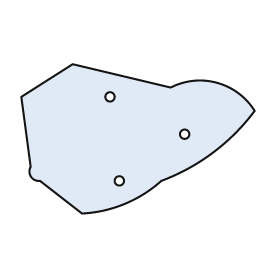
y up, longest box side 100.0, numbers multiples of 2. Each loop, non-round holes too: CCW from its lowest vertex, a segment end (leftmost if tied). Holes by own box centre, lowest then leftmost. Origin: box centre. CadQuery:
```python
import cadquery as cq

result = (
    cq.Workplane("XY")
    .moveTo(-24.0, -32.0)
    .threePointArc((-6.0, -28.0), (10.0, -18.0))
    .threePointArc((32.0, -6.0), (50.0, 12.0))
    .threePointArc((34.0, 24.0), (14.0, 22.0))
    .lineTo(-28.0, 32.0)
    .lineTo(-50.0, 18.0)
    .lineTo(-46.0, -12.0)
    .threePointArc((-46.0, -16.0), (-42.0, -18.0))
    .close()
    .moveTo(-8.0, -18.0)
    .circle(2.0)
    .moveTo(20.0, 2.0)
    .circle(2.0)
    .moveTo(-12.0, 18.0)
    .circle(2.0)
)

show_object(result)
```